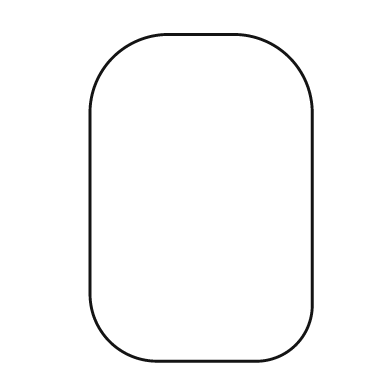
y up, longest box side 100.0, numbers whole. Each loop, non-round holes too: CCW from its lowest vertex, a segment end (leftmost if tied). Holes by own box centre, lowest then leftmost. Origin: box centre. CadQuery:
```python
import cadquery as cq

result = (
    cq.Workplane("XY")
    .moveTo(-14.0, -50.0)
    .lineTo(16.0, -50.0)
    .threePointArc((29.0, -45.0), (34.0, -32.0))
    .lineTo(34.0, 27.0)
    .threePointArc((27.0, 43.0), (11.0, 50.0))
    .lineTo(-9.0, 50.0)
    .threePointArc((-27.0, 43.0), (-34.0, 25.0))
    .lineTo(-34.0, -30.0)
    .threePointArc((-28.0, -44.0), (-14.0, -50.0))
    .close()
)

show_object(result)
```